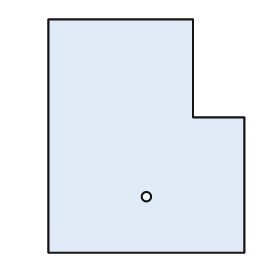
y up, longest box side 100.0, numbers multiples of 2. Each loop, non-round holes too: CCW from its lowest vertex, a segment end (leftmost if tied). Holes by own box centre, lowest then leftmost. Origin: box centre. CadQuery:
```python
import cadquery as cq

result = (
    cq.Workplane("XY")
    .moveTo(-42.0, -50.0)
    .lineTo(42.0, -50.0)
    .lineTo(42.0, 8.0)
    .lineTo(20.0, 8.0)
    .lineTo(20.0, 50.0)
    .lineTo(-42.0, 50.0)
    .close()
    .moveTo(0.0, -26.0)
    .circle(2.0)
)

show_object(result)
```